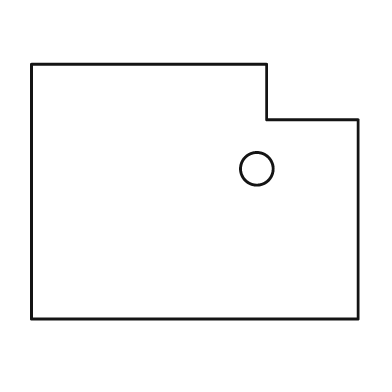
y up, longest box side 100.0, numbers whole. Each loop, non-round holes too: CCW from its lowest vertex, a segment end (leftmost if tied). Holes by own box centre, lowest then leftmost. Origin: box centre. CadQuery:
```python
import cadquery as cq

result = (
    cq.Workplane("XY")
    .moveTo(-50.0, -39.0)
    .lineTo(50.0, -39.0)
    .lineTo(50.0, 22.0)
    .lineTo(22.0, 22.0)
    .lineTo(22.0, 39.0)
    .lineTo(-50.0, 39.0)
    .close()
    .moveTo(19.0, 7.0)
    .circle(5.0)
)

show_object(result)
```